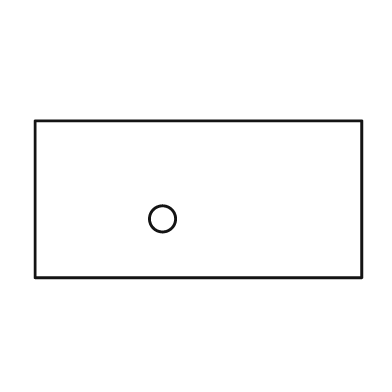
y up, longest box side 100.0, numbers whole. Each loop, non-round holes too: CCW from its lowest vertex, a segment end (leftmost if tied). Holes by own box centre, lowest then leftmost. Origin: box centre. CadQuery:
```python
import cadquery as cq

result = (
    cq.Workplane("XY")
    .moveTo(-50.0, -24.0)
    .lineTo(50.0, -24.0)
    .lineTo(50.0, 24.0)
    .lineTo(-50.0, 24.0)
    .close()
    .moveTo(-11.0, -6.0)
    .circle(4.0)
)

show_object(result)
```